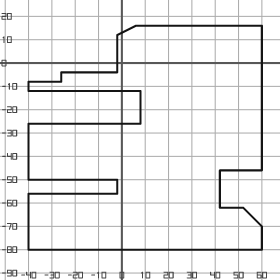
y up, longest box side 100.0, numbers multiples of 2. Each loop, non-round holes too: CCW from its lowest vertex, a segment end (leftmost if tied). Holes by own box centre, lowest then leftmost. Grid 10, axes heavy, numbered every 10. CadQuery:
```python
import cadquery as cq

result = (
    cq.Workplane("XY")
    .moveTo(-40.0, -80.0)
    .lineTo(60.0, -80.0)
    .lineTo(60.0, -70.0)
    .lineTo(52.0, -62.0)
    .lineTo(42.0, -62.0)
    .lineTo(42.0, -46.0)
    .lineTo(60.0, -46.0)
    .lineTo(60.0, 16.0)
    .lineTo(6.0, 16.0)
    .lineTo(-2.0, 12.0)
    .lineTo(-2.0, -4.0)
    .lineTo(-26.0, -4.0)
    .lineTo(-26.0, -8.0)
    .lineTo(-40.0, -8.0)
    .lineTo(-40.0, -12.0)
    .lineTo(8.0, -12.0)
    .lineTo(8.0, -26.0)
    .lineTo(-40.0, -26.0)
    .lineTo(-40.0, -50.0)
    .lineTo(-2.0, -50.0)
    .lineTo(-2.0, -56.0)
    .lineTo(-40.0, -56.0)
    .close()
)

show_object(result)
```